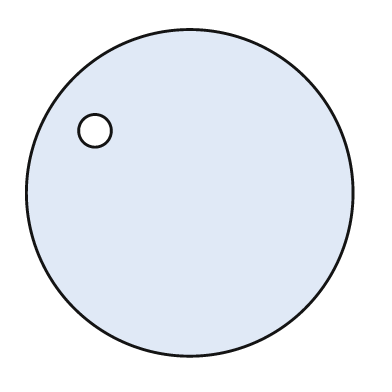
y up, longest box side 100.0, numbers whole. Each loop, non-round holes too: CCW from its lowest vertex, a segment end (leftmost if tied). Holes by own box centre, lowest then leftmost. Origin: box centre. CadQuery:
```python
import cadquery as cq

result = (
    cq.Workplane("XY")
    .moveTo(0.0, 0.0)
    .circle(50.0)
    .moveTo(-29.0, 19.0)
    .circle(5.0)
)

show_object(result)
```